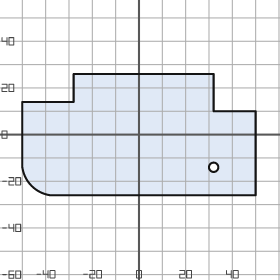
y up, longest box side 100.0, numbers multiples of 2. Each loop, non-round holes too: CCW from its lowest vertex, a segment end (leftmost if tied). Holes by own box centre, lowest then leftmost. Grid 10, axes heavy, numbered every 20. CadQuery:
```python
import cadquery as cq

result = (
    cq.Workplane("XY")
    .moveTo(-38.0, -26.0)
    .lineTo(50.0, -26.0)
    .lineTo(50.0, 10.0)
    .lineTo(32.0, 10.0)
    .lineTo(32.0, 26.0)
    .lineTo(-28.0, 26.0)
    .lineTo(-28.0, 14.0)
    .lineTo(-50.0, 14.0)
    .lineTo(-50.0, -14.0)
    .threePointArc((-46.0, -22.0), (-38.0, -26.0))
    .close()
    .moveTo(32.0, -14.0)
    .circle(2.0)
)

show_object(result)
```